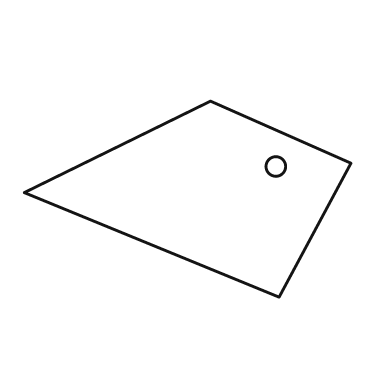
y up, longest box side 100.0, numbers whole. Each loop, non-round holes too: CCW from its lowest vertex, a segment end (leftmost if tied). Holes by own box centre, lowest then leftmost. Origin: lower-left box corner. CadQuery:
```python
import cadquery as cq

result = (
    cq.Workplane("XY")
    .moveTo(78.0, 0.0)
    .lineTo(100.0, 41.0)
    .lineTo(57.0, 60.0)
    .lineTo(0.0, 32.0)
    .close()
    .moveTo(77.0, 40.0)
    .circle(3.0)
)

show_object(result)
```